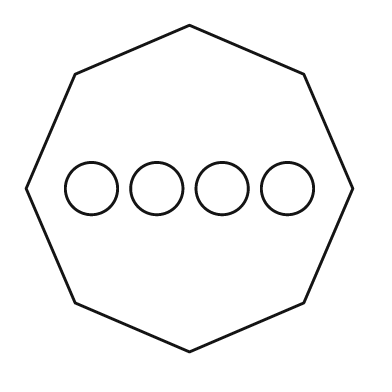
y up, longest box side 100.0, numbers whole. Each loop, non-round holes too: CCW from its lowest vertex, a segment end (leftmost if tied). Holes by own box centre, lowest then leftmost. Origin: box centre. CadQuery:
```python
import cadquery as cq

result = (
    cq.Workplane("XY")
    .moveTo(0.0, -50.0)
    .lineTo(35.0, -35.0)
    .lineTo(50.0, 0.0)
    .lineTo(35.0, 35.0)
    .lineTo(0.0, 50.0)
    .lineTo(-35.0, 35.0)
    .lineTo(-50.0, 0.0)
    .lineTo(-35.0, -35.0)
    .close()
    .moveTo(-30.0, 0.0)
    .circle(8.0)
    .moveTo(-10.0, 0.0)
    .circle(8.0)
    .moveTo(10.0, 0.0)
    .circle(8.0)
    .moveTo(30.0, 0.0)
    .circle(8.0)
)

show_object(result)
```